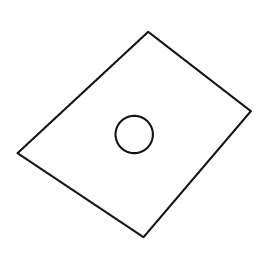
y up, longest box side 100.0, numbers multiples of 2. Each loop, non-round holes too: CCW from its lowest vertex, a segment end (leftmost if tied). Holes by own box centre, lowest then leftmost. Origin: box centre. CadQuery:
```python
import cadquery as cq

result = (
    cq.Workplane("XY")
    .moveTo(4.0, -44.0)
    .lineTo(50.0, 10.0)
    .lineTo(6.0, 44.0)
    .lineTo(-50.0, -8.0)
    .close()
    .moveTo(0.0, 0.0)
    .circle(8.0)
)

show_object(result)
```